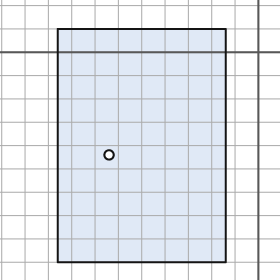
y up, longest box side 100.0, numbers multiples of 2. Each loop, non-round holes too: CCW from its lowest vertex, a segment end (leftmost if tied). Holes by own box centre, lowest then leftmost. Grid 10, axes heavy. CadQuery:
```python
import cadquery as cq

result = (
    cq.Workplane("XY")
    .moveTo(-86.0, -90.0)
    .lineTo(-14.0, -90.0)
    .lineTo(-14.0, 10.0)
    .lineTo(-86.0, 10.0)
    .close()
    .moveTo(-64.0, -44.0)
    .circle(2.0)
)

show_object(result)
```